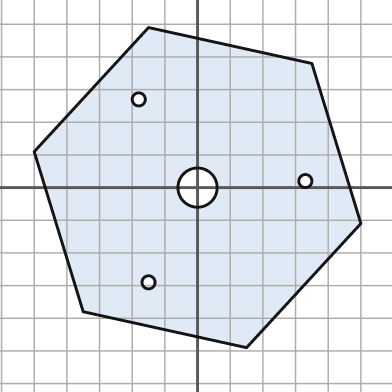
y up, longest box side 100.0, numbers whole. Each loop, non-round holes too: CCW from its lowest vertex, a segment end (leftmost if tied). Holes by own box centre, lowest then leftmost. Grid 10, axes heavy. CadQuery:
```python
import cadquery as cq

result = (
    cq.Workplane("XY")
    .moveTo(15.0, -49.0)
    .lineTo(50.0, -11.0)
    .lineTo(35.0, 38.0)
    .lineTo(-15.0, 49.0)
    .lineTo(-50.0, 11.0)
    .lineTo(-35.0, -38.0)
    .close()
    .moveTo(-15.0, -29.0)
    .circle(2.0)
    .moveTo(0.0, 0.0)
    .circle(6.0)
    .moveTo(33.0, 2.0)
    .circle(2.0)
    .moveTo(-18.0, 27.0)
    .circle(2.0)
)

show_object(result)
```